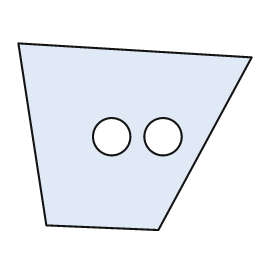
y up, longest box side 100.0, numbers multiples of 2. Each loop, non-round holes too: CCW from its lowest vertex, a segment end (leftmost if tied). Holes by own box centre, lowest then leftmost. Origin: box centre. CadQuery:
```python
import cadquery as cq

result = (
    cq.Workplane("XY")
    .moveTo(10.0, -40.0)
    .lineTo(50.0, 34.0)
    .lineTo(-50.0, 40.0)
    .lineTo(-38.0, -38.0)
    .close()
    .moveTo(-10.0, 0.0)
    .circle(8.0)
    .moveTo(12.0, 0.0)
    .circle(8.0)
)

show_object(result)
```